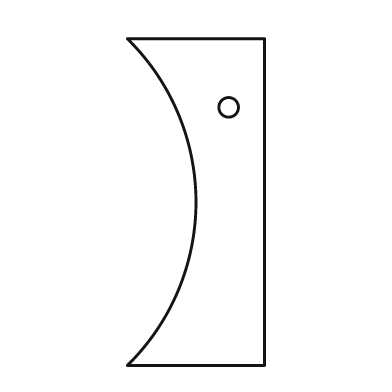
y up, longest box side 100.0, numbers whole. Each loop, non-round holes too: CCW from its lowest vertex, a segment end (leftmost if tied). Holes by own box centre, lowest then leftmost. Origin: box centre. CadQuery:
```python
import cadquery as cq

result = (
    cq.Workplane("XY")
    .moveTo(-21.0, -50.0)
    .lineTo(21.0, -50.0)
    .lineTo(21.0, 50.0)
    .lineTo(-21.0, 50.0)
    .threePointArc((0.0, 0.0), (-21.0, -50.0))
    .close()
    .moveTo(10.0, 29.0)
    .circle(3.0)
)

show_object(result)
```